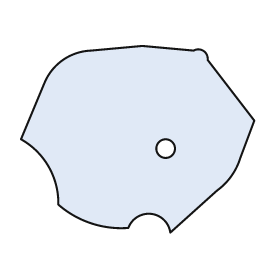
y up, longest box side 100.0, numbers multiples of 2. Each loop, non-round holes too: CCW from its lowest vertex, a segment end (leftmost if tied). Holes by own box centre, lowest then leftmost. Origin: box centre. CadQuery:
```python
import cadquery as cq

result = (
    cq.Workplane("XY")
    .moveTo(14.0, -40.0)
    .lineTo(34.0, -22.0)
    .threePointArc((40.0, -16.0), (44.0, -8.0))
    .lineTo(50.0, 8.0)
    .lineTo(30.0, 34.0)
    .threePointArc((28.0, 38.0), (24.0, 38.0))
    .lineTo(2.0, 40.0)
    .lineTo(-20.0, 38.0)
    .threePointArc((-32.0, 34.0), (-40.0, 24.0))
    .lineTo(-50.0, 0.0)
    .threePointArc((-38.0, -12.0), (-34.0, -28.0))
    .threePointArc((-20.0, -36.0), (-4.0, -38.0))
    .threePointArc((6.0, -32.0), (14.0, -40.0))
    .close()
    .moveTo(12.0, -4.0)
    .circle(4.0)
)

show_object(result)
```